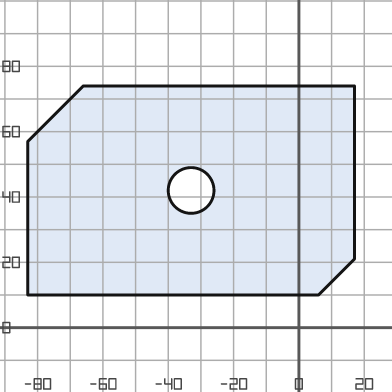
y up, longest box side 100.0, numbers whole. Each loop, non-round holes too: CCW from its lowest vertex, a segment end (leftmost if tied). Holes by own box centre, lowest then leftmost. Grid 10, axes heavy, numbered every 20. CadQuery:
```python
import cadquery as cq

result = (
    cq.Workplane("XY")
    .moveTo(-83.0, 10.0)
    .lineTo(6.0, 10.0)
    .lineTo(17.0, 21.0)
    .lineTo(17.0, 74.0)
    .lineTo(-66.0, 74.0)
    .lineTo(-83.0, 57.0)
    .close()
    .moveTo(-33.0, 42.0)
    .circle(7.0)
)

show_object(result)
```